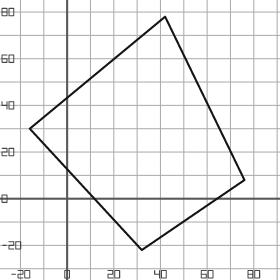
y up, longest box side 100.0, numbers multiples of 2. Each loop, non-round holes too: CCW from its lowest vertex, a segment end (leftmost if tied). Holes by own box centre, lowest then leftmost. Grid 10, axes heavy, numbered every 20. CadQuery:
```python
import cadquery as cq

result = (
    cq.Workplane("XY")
    .moveTo(32.0, -22.0)
    .lineTo(76.0, 8.0)
    .lineTo(42.0, 78.0)
    .lineTo(-16.0, 30.0)
    .close()
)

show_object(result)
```